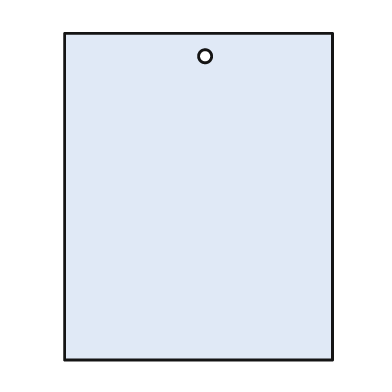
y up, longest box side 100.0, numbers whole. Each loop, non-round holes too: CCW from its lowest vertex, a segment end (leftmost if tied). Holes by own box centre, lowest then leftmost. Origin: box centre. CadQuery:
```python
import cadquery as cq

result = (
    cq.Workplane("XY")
    .moveTo(-41.0, -50.0)
    .lineTo(41.0, -50.0)
    .lineTo(41.0, 50.0)
    .lineTo(-41.0, 50.0)
    .close()
    .moveTo(2.0, 43.0)
    .circle(2.0)
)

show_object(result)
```